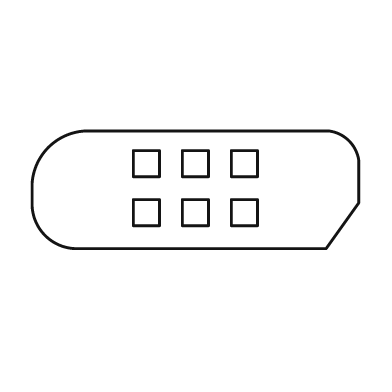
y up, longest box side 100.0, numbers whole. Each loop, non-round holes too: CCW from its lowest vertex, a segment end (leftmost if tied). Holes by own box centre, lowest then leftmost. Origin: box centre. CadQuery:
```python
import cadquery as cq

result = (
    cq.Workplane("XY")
    .moveTo(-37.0, -18.0)
    .lineTo(40.0, -18.0)
    .lineTo(50.0, -4.0)
    .lineTo(50.0, 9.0)
    .threePointArc((47.0, 15.0), (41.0, 18.0))
    .lineTo(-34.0, 18.0)
    .threePointArc((-45.0, 13.0), (-50.0, 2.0))
    .lineTo(-50.0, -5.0)
    .threePointArc((-46.0, -14.0), (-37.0, -18.0))
    .close()
    .moveTo(-19.0, -11.0)
    .lineTo(-11.0, -11.0)
    .lineTo(-11.0, -3.0)
    .lineTo(-19.0, -3.0)
    .close()
    .moveTo(-4.0, -11.0)
    .lineTo(4.0, -11.0)
    .lineTo(4.0, -3.0)
    .lineTo(-4.0, -3.0)
    .close()
    .moveTo(11.0, -11.0)
    .lineTo(19.0, -11.0)
    .lineTo(19.0, -3.0)
    .lineTo(11.0, -3.0)
    .close()
    .moveTo(-19.0, 4.0)
    .lineTo(-11.0, 4.0)
    .lineTo(-11.0, 12.0)
    .lineTo(-19.0, 12.0)
    .close()
    .moveTo(-4.0, 4.0)
    .lineTo(4.0, 4.0)
    .lineTo(4.0, 12.0)
    .lineTo(-4.0, 12.0)
    .close()
    .moveTo(11.0, 4.0)
    .lineTo(19.0, 4.0)
    .lineTo(19.0, 12.0)
    .lineTo(11.0, 12.0)
    .close()
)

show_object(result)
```